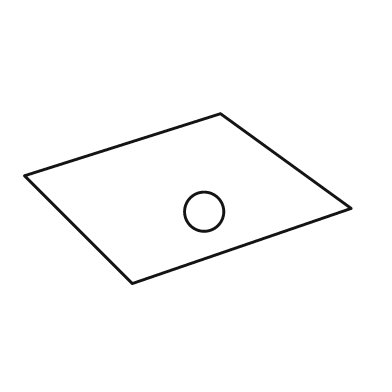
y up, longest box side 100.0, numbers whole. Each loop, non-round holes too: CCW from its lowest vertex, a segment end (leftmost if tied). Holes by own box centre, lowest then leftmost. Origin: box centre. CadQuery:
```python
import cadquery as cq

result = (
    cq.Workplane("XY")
    .moveTo(-17.0, -26.0)
    .lineTo(50.0, -3.0)
    .lineTo(10.0, 26.0)
    .lineTo(-50.0, 7.0)
    .close()
    .moveTo(5.0, -4.0)
    .circle(6.0)
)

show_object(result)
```